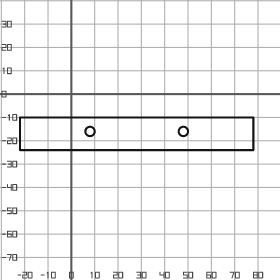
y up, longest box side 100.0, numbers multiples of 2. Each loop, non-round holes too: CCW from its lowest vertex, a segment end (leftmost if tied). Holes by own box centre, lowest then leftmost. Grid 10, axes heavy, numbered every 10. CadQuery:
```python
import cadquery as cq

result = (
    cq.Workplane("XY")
    .moveTo(-22.0, -24.0)
    .lineTo(78.0, -24.0)
    .lineTo(78.0, -10.0)
    .lineTo(-22.0, -10.0)
    .close()
    .moveTo(8.0, -16.0)
    .circle(2.0)
    .moveTo(48.0, -16.0)
    .circle(2.0)
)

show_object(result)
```